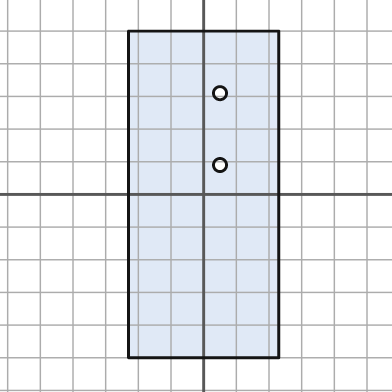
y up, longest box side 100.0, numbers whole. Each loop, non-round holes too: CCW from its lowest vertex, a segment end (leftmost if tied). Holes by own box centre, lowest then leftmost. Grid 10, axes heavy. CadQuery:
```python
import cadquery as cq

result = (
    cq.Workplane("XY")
    .moveTo(-23.0, -50.0)
    .lineTo(23.0, -50.0)
    .lineTo(23.0, 50.0)
    .lineTo(-23.0, 50.0)
    .close()
    .moveTo(5.0, 9.0)
    .circle(2.0)
    .moveTo(5.0, 31.0)
    .circle(2.0)
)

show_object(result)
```